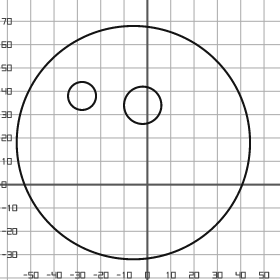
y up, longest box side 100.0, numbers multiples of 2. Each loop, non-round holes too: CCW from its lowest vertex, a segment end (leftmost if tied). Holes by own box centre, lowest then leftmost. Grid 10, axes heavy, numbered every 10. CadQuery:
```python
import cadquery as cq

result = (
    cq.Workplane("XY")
    .moveTo(-6.0, 18.0)
    .circle(50.0)
    .moveTo(-2.0, 34.0)
    .circle(8.0)
    .moveTo(-28.0, 38.0)
    .circle(6.0)
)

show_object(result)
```